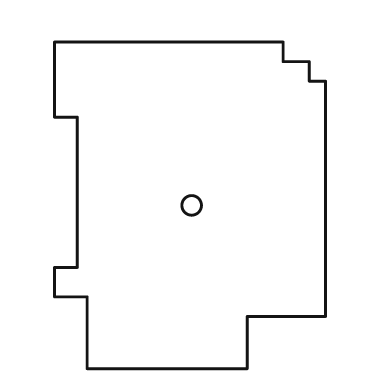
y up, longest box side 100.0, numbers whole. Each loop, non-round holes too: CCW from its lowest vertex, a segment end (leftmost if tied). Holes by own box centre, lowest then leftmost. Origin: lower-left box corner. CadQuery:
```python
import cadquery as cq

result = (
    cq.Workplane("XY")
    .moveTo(10.0, 0.0)
    .lineTo(59.0, 0.0)
    .lineTo(59.0, 16.0)
    .lineTo(83.0, 16.0)
    .lineTo(83.0, 88.0)
    .lineTo(78.0, 88.0)
    .lineTo(78.0, 94.0)
    .lineTo(70.0, 94.0)
    .lineTo(70.0, 100.0)
    .lineTo(0.0, 100.0)
    .lineTo(0.0, 77.0)
    .lineTo(7.0, 77.0)
    .lineTo(7.0, 31.0)
    .lineTo(0.0, 31.0)
    .lineTo(0.0, 22.0)
    .lineTo(10.0, 22.0)
    .close()
    .moveTo(42.0, 50.0)
    .circle(3.0)
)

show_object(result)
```